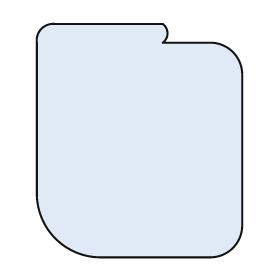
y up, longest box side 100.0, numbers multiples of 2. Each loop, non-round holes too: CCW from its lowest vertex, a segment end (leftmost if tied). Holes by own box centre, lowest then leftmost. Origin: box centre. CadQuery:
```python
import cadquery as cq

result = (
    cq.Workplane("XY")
    .moveTo(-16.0, -50.0)
    .lineTo(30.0, -50.0)
    .threePointArc((40.0, -46.0), (44.0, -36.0))
    .lineTo(44.0, 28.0)
    .threePointArc((40.0, 38.0), (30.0, 42.0))
    .lineTo(10.0, 42.0)
    .threePointArc((12.0, 46.0), (10.0, 50.0))
    .lineTo(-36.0, 50.0)
    .threePointArc((-42.0, 48.0), (-44.0, 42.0))
    .lineTo(-44.0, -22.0)
    .threePointArc((-36.0, -42.0), (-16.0, -50.0))
    .close()
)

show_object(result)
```